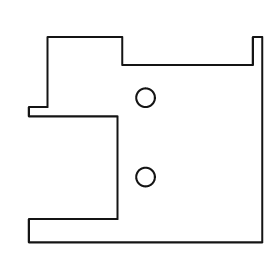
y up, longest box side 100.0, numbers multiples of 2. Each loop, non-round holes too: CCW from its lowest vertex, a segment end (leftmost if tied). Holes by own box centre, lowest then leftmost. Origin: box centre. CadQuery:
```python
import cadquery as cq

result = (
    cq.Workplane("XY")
    .moveTo(-50.0, -44.0)
    .lineTo(50.0, -44.0)
    .lineTo(50.0, 44.0)
    .lineTo(46.0, 44.0)
    .lineTo(46.0, 32.0)
    .lineTo(-10.0, 32.0)
    .lineTo(-10.0, 44.0)
    .lineTo(-42.0, 44.0)
    .lineTo(-42.0, 14.0)
    .lineTo(-50.0, 14.0)
    .lineTo(-50.0, 10.0)
    .lineTo(-12.0, 10.0)
    .lineTo(-12.0, -34.0)
    .lineTo(-50.0, -34.0)
    .close()
    .moveTo(0.0, -16.0)
    .circle(4.0)
    .moveTo(0.0, 18.0)
    .circle(4.0)
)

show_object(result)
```